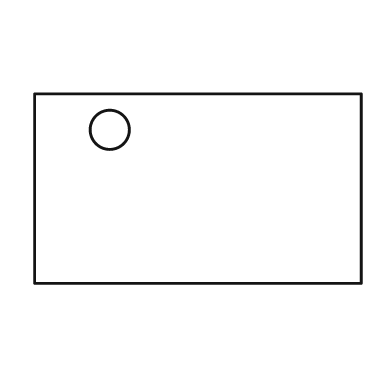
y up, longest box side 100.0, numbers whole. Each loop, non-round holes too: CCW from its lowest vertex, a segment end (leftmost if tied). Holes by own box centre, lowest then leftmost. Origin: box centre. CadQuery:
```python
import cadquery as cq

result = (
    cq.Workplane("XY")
    .moveTo(-50.0, -29.0)
    .lineTo(50.0, -29.0)
    .lineTo(50.0, 29.0)
    .lineTo(-50.0, 29.0)
    .close()
    .moveTo(-27.0, 18.0)
    .circle(6.0)
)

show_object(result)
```